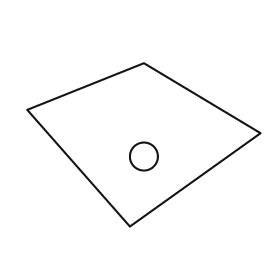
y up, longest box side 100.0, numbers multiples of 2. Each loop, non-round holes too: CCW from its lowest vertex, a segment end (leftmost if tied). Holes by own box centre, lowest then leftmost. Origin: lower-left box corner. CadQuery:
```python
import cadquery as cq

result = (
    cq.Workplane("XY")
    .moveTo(44.0, 0.0)
    .lineTo(100.0, 40.0)
    .lineTo(50.0, 70.0)
    .lineTo(0.0, 50.0)
    .close()
    .moveTo(50.0, 30.0)
    .circle(6.0)
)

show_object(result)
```